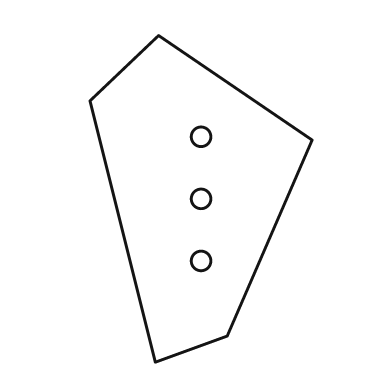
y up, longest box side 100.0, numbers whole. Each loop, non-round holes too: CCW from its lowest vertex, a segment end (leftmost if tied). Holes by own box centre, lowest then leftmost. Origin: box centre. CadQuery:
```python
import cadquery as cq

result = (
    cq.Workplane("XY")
    .moveTo(-14.0, -50.0)
    .lineTo(8.0, -42.0)
    .lineTo(34.0, 18.0)
    .lineTo(-13.0, 50.0)
    .lineTo(-34.0, 30.0)
    .close()
    .moveTo(0.0, -19.0)
    .circle(3.0)
    .moveTo(0.0, 0.0)
    .circle(3.0)
    .moveTo(0.0, 19.0)
    .circle(3.0)
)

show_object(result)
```